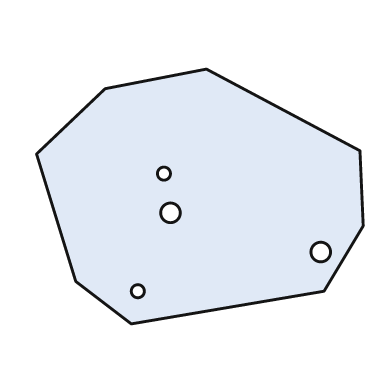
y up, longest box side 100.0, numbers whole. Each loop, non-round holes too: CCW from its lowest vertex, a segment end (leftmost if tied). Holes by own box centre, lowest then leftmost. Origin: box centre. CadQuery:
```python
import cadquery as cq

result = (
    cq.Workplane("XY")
    .moveTo(-21.0, -39.0)
    .lineTo(38.0, -29.0)
    .lineTo(50.0, -9.0)
    .lineTo(49.0, 14.0)
    .lineTo(2.0, 39.0)
    .lineTo(-29.0, 33.0)
    .lineTo(-50.0, 13.0)
    .lineTo(-38.0, -26.0)
    .close()
    .moveTo(-19.0, -29.0)
    .circle(2.0)
    .moveTo(37.0, -17.0)
    .circle(3.0)
    .moveTo(-9.0, -5.0)
    .circle(3.0)
    .moveTo(-11.0, 7.0)
    .circle(2.0)
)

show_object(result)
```